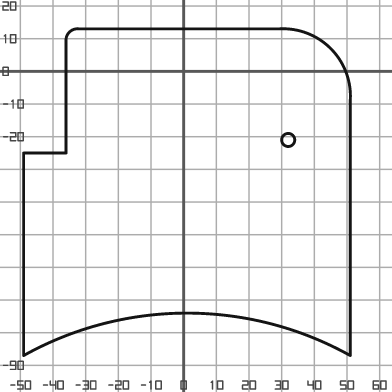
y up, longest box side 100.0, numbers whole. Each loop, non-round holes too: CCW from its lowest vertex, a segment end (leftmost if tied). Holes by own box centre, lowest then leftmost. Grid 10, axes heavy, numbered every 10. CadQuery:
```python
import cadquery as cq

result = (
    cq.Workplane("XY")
    .moveTo(-49.0, -87.0)
    .threePointArc((1.0, -74.0), (51.0, -87.0))
    .lineTo(51.0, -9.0)
    .threePointArc((45.0, 7.0), (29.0, 13.0))
    .lineTo(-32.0, 13.0)
    .threePointArc((-35.0, 12.0), (-36.0, 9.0))
    .lineTo(-36.0, -25.0)
    .lineTo(-49.0, -25.0)
    .close()
    .moveTo(32.0, -21.0)
    .circle(2.0)
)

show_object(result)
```